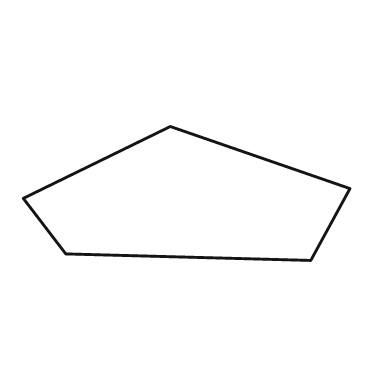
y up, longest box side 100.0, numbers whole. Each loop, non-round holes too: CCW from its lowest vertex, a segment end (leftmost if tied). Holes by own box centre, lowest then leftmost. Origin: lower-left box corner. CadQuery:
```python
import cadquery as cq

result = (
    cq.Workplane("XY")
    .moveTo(88.0, 0.0)
    .lineTo(100.0, 22.0)
    .lineTo(45.0, 41.0)
    .lineTo(0.0, 19.0)
    .lineTo(13.0, 2.0)
    .close()
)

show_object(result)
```